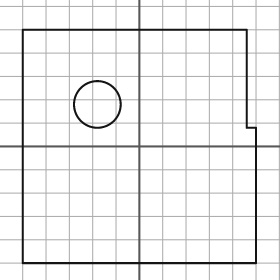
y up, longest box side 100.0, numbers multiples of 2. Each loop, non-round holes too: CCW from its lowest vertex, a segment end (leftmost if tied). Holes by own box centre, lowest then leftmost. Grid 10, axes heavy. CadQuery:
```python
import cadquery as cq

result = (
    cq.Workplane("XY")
    .moveTo(-50.0, -50.0)
    .lineTo(50.0, -50.0)
    .lineTo(50.0, 8.0)
    .lineTo(46.0, 8.0)
    .lineTo(46.0, 50.0)
    .lineTo(-50.0, 50.0)
    .close()
    .moveTo(-18.0, 18.0)
    .circle(10.0)
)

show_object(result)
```